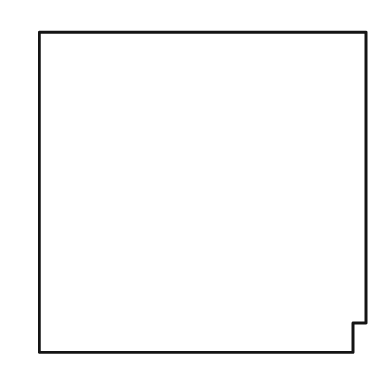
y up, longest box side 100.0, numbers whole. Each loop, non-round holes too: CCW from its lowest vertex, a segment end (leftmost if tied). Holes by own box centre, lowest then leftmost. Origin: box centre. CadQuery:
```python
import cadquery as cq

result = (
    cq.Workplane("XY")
    .moveTo(-50.0, -49.0)
    .lineTo(46.0, -49.0)
    .lineTo(46.0, -40.0)
    .lineTo(50.0, -40.0)
    .lineTo(50.0, 49.0)
    .lineTo(-50.0, 49.0)
    .close()
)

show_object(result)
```